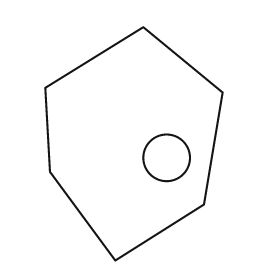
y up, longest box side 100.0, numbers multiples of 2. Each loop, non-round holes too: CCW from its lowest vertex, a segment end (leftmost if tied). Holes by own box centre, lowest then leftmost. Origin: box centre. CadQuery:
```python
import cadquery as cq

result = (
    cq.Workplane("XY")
    .moveTo(-8.0, -50.0)
    .lineTo(30.0, -26.0)
    .lineTo(38.0, 22.0)
    .lineTo(4.0, 50.0)
    .lineTo(-38.0, 24.0)
    .lineTo(-36.0, -12.0)
    .close()
    .moveTo(14.0, -6.0)
    .circle(10.0)
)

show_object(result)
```